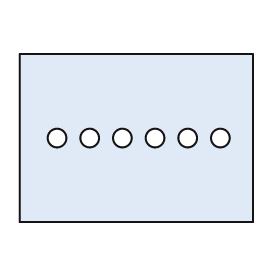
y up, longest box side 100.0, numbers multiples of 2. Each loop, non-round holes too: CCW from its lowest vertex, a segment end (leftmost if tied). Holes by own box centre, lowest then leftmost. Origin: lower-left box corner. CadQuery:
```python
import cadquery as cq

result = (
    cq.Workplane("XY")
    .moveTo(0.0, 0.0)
    .lineTo(100.0, 0.0)
    .lineTo(100.0, 72.0)
    .lineTo(0.0, 72.0)
    .close()
    .moveTo(16.0, 36.0)
    .circle(4.0)
    .moveTo(30.0, 36.0)
    .circle(4.0)
    .moveTo(44.0, 36.0)
    .circle(4.0)
    .moveTo(58.0, 36.0)
    .circle(4.0)
    .moveTo(72.0, 36.0)
    .circle(4.0)
    .moveTo(86.0, 36.0)
    .circle(4.0)
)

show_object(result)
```